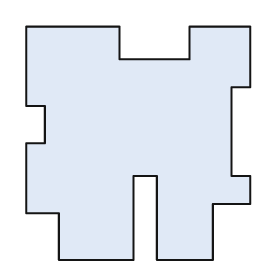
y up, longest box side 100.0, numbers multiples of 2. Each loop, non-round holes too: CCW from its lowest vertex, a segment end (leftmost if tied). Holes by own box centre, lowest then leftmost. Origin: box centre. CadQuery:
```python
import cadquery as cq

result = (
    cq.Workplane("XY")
    .moveTo(-34.0, -50.0)
    .lineTo(-2.0, -50.0)
    .lineTo(-2.0, -14.0)
    .lineTo(8.0, -14.0)
    .lineTo(8.0, -50.0)
    .lineTo(32.0, -50.0)
    .lineTo(32.0, -26.0)
    .lineTo(48.0, -26.0)
    .lineTo(48.0, -14.0)
    .lineTo(40.0, -14.0)
    .lineTo(40.0, 24.0)
    .lineTo(48.0, 24.0)
    .lineTo(48.0, 50.0)
    .lineTo(22.0, 50.0)
    .lineTo(22.0, 36.0)
    .lineTo(-8.0, 36.0)
    .lineTo(-8.0, 50.0)
    .lineTo(-48.0, 50.0)
    .lineTo(-48.0, 16.0)
    .lineTo(-40.0, 16.0)
    .lineTo(-40.0, 0.0)
    .lineTo(-48.0, 0.0)
    .lineTo(-48.0, -30.0)
    .lineTo(-34.0, -30.0)
    .close()
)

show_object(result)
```